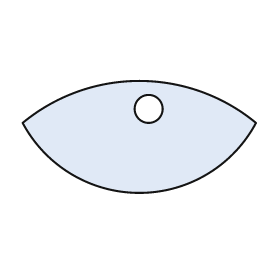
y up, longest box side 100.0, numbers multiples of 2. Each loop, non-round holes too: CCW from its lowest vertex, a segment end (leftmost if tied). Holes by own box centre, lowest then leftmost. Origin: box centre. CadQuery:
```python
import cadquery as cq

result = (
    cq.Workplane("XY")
    .moveTo(-50.0, 6.0)
    .threePointArc((0.0, -24.0), (50.0, 6.0))
    .threePointArc((0.0, 24.0), (-50.0, 6.0))
    .close()
    .moveTo(4.0, 12.0)
    .circle(6.0)
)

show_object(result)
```